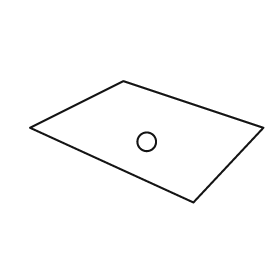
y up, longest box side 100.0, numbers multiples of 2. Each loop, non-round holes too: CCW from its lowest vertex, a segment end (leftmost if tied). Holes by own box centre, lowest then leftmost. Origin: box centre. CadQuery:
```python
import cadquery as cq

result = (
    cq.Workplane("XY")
    .moveTo(20.0, -26.0)
    .lineTo(50.0, 6.0)
    .lineTo(-10.0, 26.0)
    .lineTo(-50.0, 6.0)
    .close()
    .moveTo(0.0, 0.0)
    .circle(4.0)
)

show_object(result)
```